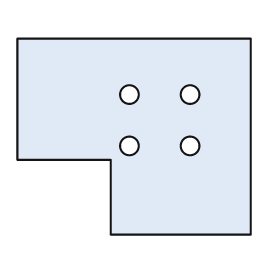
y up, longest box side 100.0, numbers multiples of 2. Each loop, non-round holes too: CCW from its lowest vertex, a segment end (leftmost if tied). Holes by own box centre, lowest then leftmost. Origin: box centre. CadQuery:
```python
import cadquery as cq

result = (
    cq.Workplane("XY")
    .moveTo(-10.0, -42.0)
    .lineTo(50.0, -42.0)
    .lineTo(50.0, 42.0)
    .lineTo(-50.0, 42.0)
    .lineTo(-50.0, -10.0)
    .lineTo(-10.0, -10.0)
    .close()
    .moveTo(-2.0, -4.0)
    .circle(4.0)
    .moveTo(24.0, -4.0)
    .circle(4.0)
    .moveTo(-2.0, 18.0)
    .circle(4.0)
    .moveTo(24.0, 18.0)
    .circle(4.0)
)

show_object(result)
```